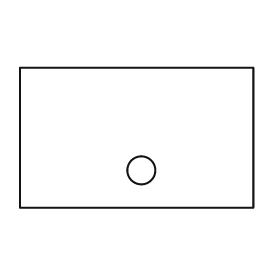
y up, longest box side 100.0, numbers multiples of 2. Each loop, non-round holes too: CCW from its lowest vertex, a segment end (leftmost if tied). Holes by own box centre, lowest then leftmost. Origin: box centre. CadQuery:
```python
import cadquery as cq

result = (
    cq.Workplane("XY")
    .moveTo(-50.0, -30.0)
    .lineTo(50.0, -30.0)
    .lineTo(50.0, 30.0)
    .lineTo(-50.0, 30.0)
    .close()
    .moveTo(2.0, -14.0)
    .circle(6.0)
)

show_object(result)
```